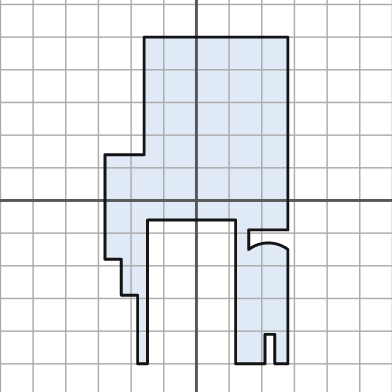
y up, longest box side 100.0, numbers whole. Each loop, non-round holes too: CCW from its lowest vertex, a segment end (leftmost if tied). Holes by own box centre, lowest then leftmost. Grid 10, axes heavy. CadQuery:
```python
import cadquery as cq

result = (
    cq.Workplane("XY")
    .moveTo(-18.0, -50.0)
    .lineTo(-15.0, -50.0)
    .lineTo(-15.0, -6.0)
    .lineTo(12.0, -6.0)
    .lineTo(12.0, -50.0)
    .lineTo(21.0, -50.0)
    .lineTo(21.0, -41.0)
    .lineTo(24.0, -41.0)
    .lineTo(24.0, -50.0)
    .lineTo(28.0, -50.0)
    .lineTo(28.0, -15.0)
    .threePointArc((22.0, -13.0), (16.0, -15.0))
    .lineTo(16.0, -9.0)
    .lineTo(28.0, -9.0)
    .lineTo(28.0, 50.0)
    .lineTo(-16.0, 50.0)
    .lineTo(-16.0, 14.0)
    .lineTo(-28.0, 14.0)
    .lineTo(-28.0, -18.0)
    .lineTo(-23.0, -18.0)
    .lineTo(-23.0, -29.0)
    .lineTo(-18.0, -29.0)
    .close()
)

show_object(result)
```